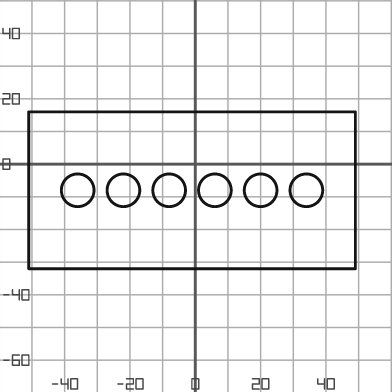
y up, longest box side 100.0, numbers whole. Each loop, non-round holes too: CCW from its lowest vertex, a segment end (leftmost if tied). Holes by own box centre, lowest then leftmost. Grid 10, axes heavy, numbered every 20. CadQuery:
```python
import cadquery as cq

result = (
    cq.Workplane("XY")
    .moveTo(-51.0, -32.0)
    .lineTo(49.0, -32.0)
    .lineTo(49.0, 16.0)
    .lineTo(-51.0, 16.0)
    .close()
    .moveTo(-36.0, -8.0)
    .circle(5.0)
    .moveTo(-22.0, -8.0)
    .circle(5.0)
    .moveTo(-8.0, -8.0)
    .circle(5.0)
    .moveTo(6.0, -8.0)
    .circle(5.0)
    .moveTo(20.0, -8.0)
    .circle(5.0)
    .moveTo(34.0, -8.0)
    .circle(5.0)
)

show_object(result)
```